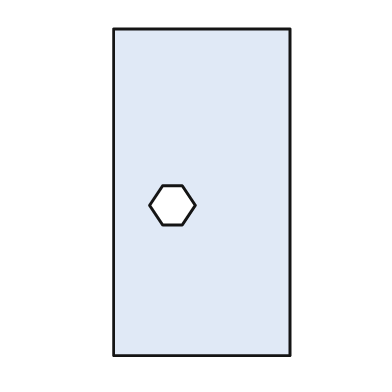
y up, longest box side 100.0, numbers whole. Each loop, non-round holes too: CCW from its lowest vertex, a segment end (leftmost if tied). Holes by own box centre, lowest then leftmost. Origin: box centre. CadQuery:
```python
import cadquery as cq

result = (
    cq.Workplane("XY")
    .moveTo(-27.0, -50.0)
    .lineTo(27.0, -50.0)
    .lineTo(27.0, 50.0)
    .lineTo(-27.0, 50.0)
    .close()
    .moveTo(-12.0, -10.0)
    .lineTo(-6.0, -10.0)
    .lineTo(-2.0, -4.0)
    .lineTo(-6.0, 2.0)
    .lineTo(-12.0, 2.0)
    .lineTo(-16.0, -4.0)
    .close()
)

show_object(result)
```